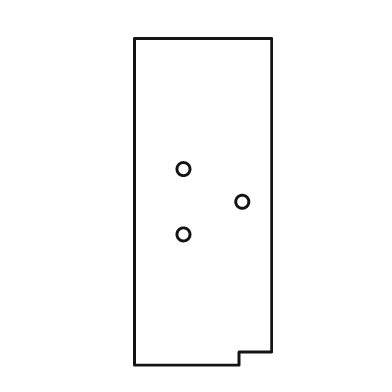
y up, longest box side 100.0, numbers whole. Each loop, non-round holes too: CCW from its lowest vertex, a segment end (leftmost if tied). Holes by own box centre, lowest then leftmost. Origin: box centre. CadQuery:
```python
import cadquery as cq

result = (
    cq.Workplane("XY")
    .moveTo(-21.0, -50.0)
    .lineTo(11.0, -50.0)
    .lineTo(11.0, -46.0)
    .lineTo(21.0, -46.0)
    .lineTo(21.0, 50.0)
    .lineTo(-21.0, 50.0)
    .close()
    .moveTo(-6.0, -10.0)
    .circle(2.0)
    .moveTo(12.0, 0.0)
    .circle(2.0)
    .moveTo(-6.0, 10.0)
    .circle(2.0)
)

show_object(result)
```